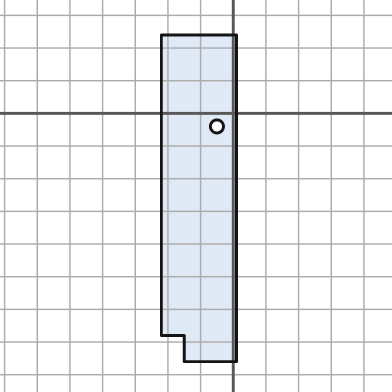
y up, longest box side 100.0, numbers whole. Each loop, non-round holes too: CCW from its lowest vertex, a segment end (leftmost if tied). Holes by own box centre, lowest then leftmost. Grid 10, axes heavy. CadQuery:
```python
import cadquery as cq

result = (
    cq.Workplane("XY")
    .moveTo(-15.0, -76.0)
    .lineTo(1.0, -76.0)
    .lineTo(1.0, 24.0)
    .lineTo(-22.0, 24.0)
    .lineTo(-22.0, -68.0)
    .lineTo(-15.0, -68.0)
    .close()
    .moveTo(-5.0, -4.0)
    .circle(2.0)
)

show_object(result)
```